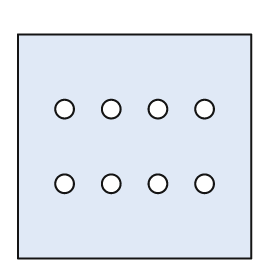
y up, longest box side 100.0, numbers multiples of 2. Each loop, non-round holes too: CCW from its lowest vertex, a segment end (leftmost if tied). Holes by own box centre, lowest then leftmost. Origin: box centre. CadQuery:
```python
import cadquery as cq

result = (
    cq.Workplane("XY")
    .moveTo(-50.0, -48.0)
    .lineTo(50.0, -48.0)
    .lineTo(50.0, 48.0)
    .lineTo(-50.0, 48.0)
    .close()
    .moveTo(-30.0, -16.0)
    .circle(4.0)
    .moveTo(-10.0, -16.0)
    .circle(4.0)
    .moveTo(10.0, -16.0)
    .circle(4.0)
    .moveTo(30.0, -16.0)
    .circle(4.0)
    .moveTo(-30.0, 16.0)
    .circle(4.0)
    .moveTo(-10.0, 16.0)
    .circle(4.0)
    .moveTo(10.0, 16.0)
    .circle(4.0)
    .moveTo(30.0, 16.0)
    .circle(4.0)
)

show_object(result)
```